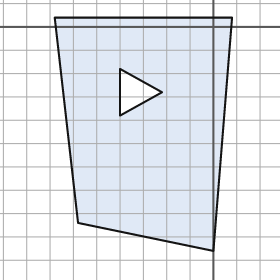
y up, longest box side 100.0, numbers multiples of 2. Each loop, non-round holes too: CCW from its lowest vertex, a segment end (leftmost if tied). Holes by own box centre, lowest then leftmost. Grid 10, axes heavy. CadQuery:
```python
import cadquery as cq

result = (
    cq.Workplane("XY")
    .moveTo(0.0, -96.0)
    .lineTo(8.0, 4.0)
    .lineTo(-68.0, 4.0)
    .lineTo(-58.0, -84.0)
    .close()
    .moveTo(-40.0, -38.0)
    .lineTo(-22.0, -28.0)
    .lineTo(-40.0, -18.0)
    .close()
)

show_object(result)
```